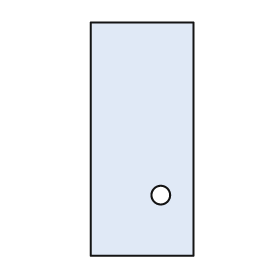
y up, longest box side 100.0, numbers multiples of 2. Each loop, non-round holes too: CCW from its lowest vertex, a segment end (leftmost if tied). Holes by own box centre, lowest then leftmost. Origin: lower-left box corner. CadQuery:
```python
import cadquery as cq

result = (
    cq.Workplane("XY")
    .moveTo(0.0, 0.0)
    .lineTo(44.0, 0.0)
    .lineTo(44.0, 100.0)
    .lineTo(0.0, 100.0)
    .close()
    .moveTo(30.0, 26.0)
    .circle(4.0)
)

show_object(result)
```